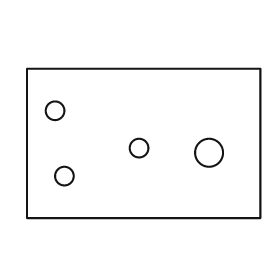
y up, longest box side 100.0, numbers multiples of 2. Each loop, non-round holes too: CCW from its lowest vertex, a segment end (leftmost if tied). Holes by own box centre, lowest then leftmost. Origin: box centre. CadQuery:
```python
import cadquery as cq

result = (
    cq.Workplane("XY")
    .moveTo(-50.0, -32.0)
    .lineTo(50.0, -32.0)
    .lineTo(50.0, 32.0)
    .lineTo(-50.0, 32.0)
    .close()
    .moveTo(-34.0, -14.0)
    .circle(4.0)
    .moveTo(28.0, -4.0)
    .circle(6.0)
    .moveTo(-2.0, -2.0)
    .circle(4.0)
    .moveTo(-38.0, 14.0)
    .circle(4.0)
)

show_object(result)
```